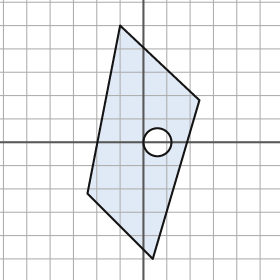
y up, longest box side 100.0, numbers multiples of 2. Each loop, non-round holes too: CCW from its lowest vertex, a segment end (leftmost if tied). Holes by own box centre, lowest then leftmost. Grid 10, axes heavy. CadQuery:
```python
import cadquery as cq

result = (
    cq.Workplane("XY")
    .moveTo(4.0, -50.0)
    .lineTo(24.0, 18.0)
    .lineTo(-10.0, 50.0)
    .lineTo(-24.0, -22.0)
    .close()
    .moveTo(6.0, 0.0)
    .circle(6.0)
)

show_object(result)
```